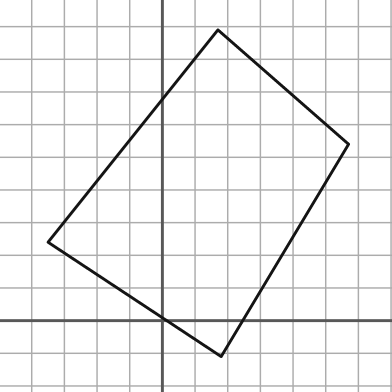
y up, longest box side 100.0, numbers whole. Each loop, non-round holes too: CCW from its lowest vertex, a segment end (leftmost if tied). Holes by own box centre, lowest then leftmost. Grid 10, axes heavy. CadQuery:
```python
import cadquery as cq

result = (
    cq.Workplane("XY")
    .moveTo(18.0, -11.0)
    .lineTo(57.0, 54.0)
    .lineTo(17.0, 89.0)
    .lineTo(-35.0, 24.0)
    .close()
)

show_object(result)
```